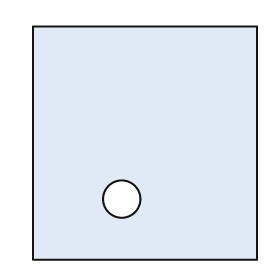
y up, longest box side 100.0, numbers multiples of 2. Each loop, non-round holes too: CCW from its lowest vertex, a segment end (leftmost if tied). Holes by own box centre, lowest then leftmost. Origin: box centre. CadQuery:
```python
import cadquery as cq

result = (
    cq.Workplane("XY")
    .moveTo(-48.0, -50.0)
    .lineTo(48.0, -50.0)
    .lineTo(48.0, 50.0)
    .lineTo(-48.0, 50.0)
    .close()
    .moveTo(-10.0, -24.0)
    .circle(8.0)
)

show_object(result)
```